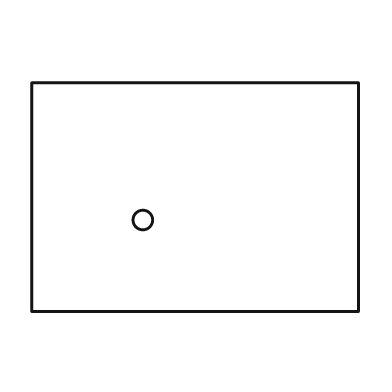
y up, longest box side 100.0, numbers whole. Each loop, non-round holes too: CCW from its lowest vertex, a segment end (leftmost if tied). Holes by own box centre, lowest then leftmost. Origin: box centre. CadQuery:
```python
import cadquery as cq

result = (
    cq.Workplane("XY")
    .moveTo(-50.0, -35.0)
    .lineTo(50.0, -35.0)
    .lineTo(50.0, 35.0)
    .lineTo(-50.0, 35.0)
    .close()
    .moveTo(-16.0, -7.0)
    .circle(3.0)
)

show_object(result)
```